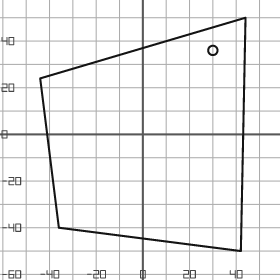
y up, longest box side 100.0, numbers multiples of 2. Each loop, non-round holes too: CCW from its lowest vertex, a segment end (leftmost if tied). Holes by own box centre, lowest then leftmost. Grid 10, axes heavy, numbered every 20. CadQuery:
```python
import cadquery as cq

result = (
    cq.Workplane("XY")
    .moveTo(42.0, -50.0)
    .lineTo(44.0, 50.0)
    .lineTo(-44.0, 24.0)
    .lineTo(-36.0, -40.0)
    .close()
    .moveTo(30.0, 36.0)
    .circle(2.0)
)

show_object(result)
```